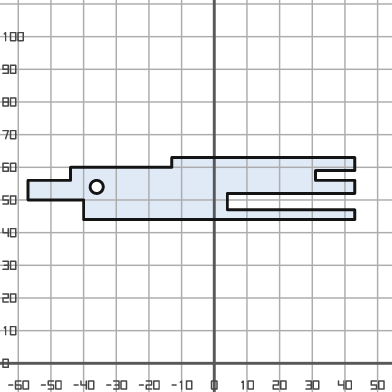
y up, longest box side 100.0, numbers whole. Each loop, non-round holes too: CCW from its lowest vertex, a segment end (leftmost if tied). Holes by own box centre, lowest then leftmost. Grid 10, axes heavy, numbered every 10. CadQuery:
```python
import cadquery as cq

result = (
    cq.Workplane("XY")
    .moveTo(-40.0, 44.0)
    .lineTo(43.0, 44.0)
    .lineTo(43.0, 47.0)
    .lineTo(4.0, 47.0)
    .lineTo(4.0, 52.0)
    .lineTo(43.0, 52.0)
    .lineTo(43.0, 56.0)
    .lineTo(31.0, 56.0)
    .lineTo(31.0, 59.0)
    .lineTo(43.0, 59.0)
    .lineTo(43.0, 63.0)
    .lineTo(-13.0, 63.0)
    .lineTo(-13.0, 60.0)
    .lineTo(-44.0, 60.0)
    .lineTo(-44.0, 56.0)
    .lineTo(-57.0, 56.0)
    .lineTo(-57.0, 50.0)
    .lineTo(-40.0, 50.0)
    .close()
    .moveTo(-36.0, 54.0)
    .circle(2.0)
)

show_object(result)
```